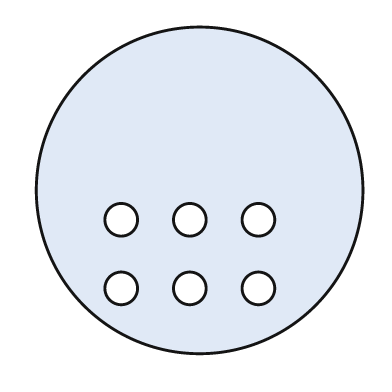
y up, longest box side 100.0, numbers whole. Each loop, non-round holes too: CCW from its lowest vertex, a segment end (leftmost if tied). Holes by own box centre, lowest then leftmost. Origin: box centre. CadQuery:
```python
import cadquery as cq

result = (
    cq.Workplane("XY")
    .moveTo(0.0, 0.0)
    .circle(50.0)
    .moveTo(-24.0, -30.0)
    .circle(5.0)
    .moveTo(-3.0, -30.0)
    .circle(5.0)
    .moveTo(18.0, -30.0)
    .circle(5.0)
    .moveTo(-24.0, -9.0)
    .circle(5.0)
    .moveTo(-3.0, -9.0)
    .circle(5.0)
    .moveTo(18.0, -9.0)
    .circle(5.0)
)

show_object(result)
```